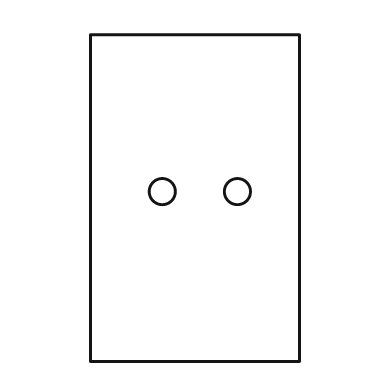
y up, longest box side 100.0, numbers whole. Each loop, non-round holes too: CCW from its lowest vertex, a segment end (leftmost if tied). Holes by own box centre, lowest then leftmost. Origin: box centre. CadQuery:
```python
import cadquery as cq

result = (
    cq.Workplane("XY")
    .moveTo(-32.0, -50.0)
    .lineTo(32.0, -50.0)
    .lineTo(32.0, 50.0)
    .lineTo(-32.0, 50.0)
    .close()
    .moveTo(-10.0, 2.0)
    .circle(4.0)
    .moveTo(13.0, 2.0)
    .circle(4.0)
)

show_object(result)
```